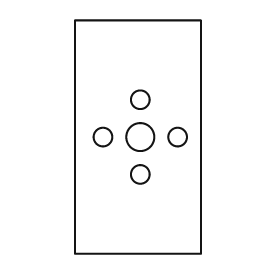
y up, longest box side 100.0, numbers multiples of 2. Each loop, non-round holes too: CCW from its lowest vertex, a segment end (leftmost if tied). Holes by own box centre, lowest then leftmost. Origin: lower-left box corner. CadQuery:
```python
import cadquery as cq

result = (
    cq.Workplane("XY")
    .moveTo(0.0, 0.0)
    .lineTo(54.0, 0.0)
    .lineTo(54.0, 100.0)
    .lineTo(0.0, 100.0)
    .close()
    .moveTo(28.0, 34.0)
    .circle(4.0)
    .moveTo(12.0, 50.0)
    .circle(4.0)
    .moveTo(28.0, 50.0)
    .circle(6.0)
    .moveTo(44.0, 50.0)
    .circle(4.0)
    .moveTo(28.0, 66.0)
    .circle(4.0)
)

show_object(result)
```